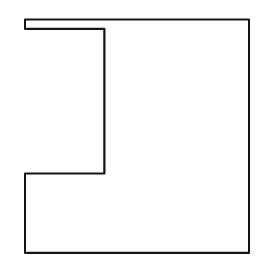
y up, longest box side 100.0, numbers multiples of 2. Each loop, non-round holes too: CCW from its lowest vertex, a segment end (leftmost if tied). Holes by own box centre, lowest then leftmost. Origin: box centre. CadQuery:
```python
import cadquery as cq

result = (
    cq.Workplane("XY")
    .moveTo(-48.0, -50.0)
    .lineTo(48.0, -50.0)
    .lineTo(48.0, 50.0)
    .lineTo(-48.0, 50.0)
    .lineTo(-48.0, 46.0)
    .lineTo(-14.0, 46.0)
    .lineTo(-14.0, -16.0)
    .lineTo(-48.0, -16.0)
    .close()
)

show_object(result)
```